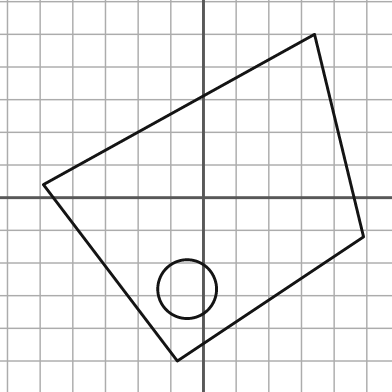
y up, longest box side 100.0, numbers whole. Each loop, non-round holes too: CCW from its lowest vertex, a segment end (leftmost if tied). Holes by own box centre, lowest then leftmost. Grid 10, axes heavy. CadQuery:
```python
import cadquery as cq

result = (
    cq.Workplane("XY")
    .moveTo(-8.0, -50.0)
    .lineTo(49.0, -12.0)
    .lineTo(34.0, 50.0)
    .lineTo(-49.0, 4.0)
    .close()
    .moveTo(-5.0, -28.0)
    .circle(9.0)
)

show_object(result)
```